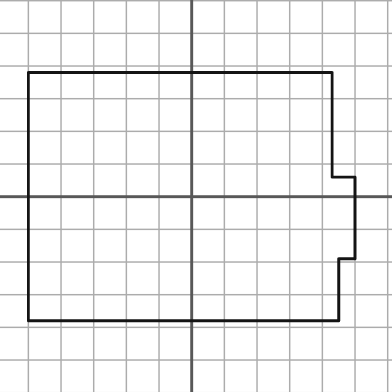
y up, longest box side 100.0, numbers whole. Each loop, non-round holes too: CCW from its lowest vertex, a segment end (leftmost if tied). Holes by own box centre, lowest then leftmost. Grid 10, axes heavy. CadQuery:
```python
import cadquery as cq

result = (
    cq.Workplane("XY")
    .moveTo(-50.0, -38.0)
    .lineTo(45.0, -38.0)
    .lineTo(45.0, -19.0)
    .lineTo(50.0, -19.0)
    .lineTo(50.0, 6.0)
    .lineTo(43.0, 6.0)
    .lineTo(43.0, 38.0)
    .lineTo(-50.0, 38.0)
    .close()
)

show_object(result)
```